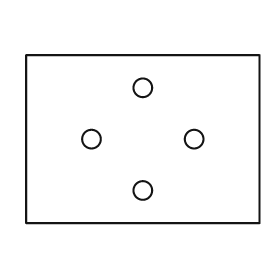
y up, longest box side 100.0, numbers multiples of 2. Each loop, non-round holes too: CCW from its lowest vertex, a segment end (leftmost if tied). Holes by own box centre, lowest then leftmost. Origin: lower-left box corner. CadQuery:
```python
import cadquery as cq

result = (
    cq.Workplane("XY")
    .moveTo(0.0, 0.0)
    .lineTo(100.0, 0.0)
    .lineTo(100.0, 72.0)
    .lineTo(0.0, 72.0)
    .close()
    .moveTo(50.0, 14.0)
    .circle(4.0)
    .moveTo(28.0, 36.0)
    .circle(4.0)
    .moveTo(72.0, 36.0)
    .circle(4.0)
    .moveTo(50.0, 58.0)
    .circle(4.0)
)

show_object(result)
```